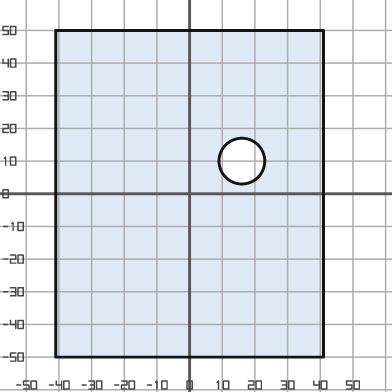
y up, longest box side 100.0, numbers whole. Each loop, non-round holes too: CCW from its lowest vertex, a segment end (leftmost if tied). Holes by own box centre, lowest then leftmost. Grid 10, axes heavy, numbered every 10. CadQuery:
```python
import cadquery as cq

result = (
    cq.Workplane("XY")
    .moveTo(-41.0, -50.0)
    .lineTo(41.0, -50.0)
    .lineTo(41.0, 50.0)
    .lineTo(-41.0, 50.0)
    .close()
    .moveTo(16.0, 10.0)
    .circle(7.0)
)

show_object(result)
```